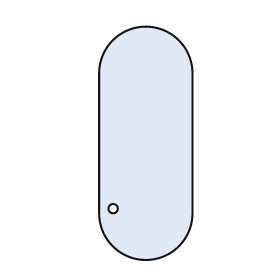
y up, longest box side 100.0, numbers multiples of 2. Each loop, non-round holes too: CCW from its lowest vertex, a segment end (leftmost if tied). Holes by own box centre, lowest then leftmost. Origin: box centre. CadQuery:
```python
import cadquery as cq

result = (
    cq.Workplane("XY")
    .moveTo(-20.0, -30.0)
    .threePointArc((0.0, -50.0), (20.0, -30.0))
    .lineTo(20.0, 30.0)
    .threePointArc((0.0, 50.0), (-20.0, 30.0))
    .close()
    .moveTo(-14.0, -28.0)
    .circle(2.0)
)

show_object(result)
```